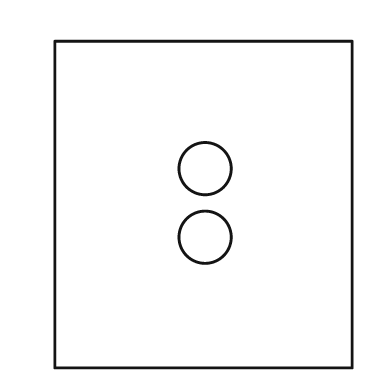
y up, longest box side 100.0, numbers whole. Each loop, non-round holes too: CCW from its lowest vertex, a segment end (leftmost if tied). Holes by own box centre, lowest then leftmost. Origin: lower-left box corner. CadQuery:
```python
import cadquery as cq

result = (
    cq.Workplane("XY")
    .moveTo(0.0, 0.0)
    .lineTo(91.0, 0.0)
    .lineTo(91.0, 100.0)
    .lineTo(0.0, 100.0)
    .close()
    .moveTo(46.0, 40.0)
    .circle(8.0)
    .moveTo(46.0, 61.0)
    .circle(8.0)
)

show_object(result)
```